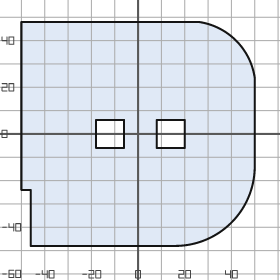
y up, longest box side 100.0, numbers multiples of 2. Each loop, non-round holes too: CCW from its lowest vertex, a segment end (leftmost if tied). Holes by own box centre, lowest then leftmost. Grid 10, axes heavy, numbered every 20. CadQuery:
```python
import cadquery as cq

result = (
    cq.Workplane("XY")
    .moveTo(-46.0, -48.0)
    .lineTo(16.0, -48.0)
    .threePointArc((40.0, -38.0), (50.0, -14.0))
    .lineTo(50.0, 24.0)
    .threePointArc((42.0, 40.0), (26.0, 48.0))
    .lineTo(-50.0, 48.0)
    .lineTo(-50.0, -24.0)
    .lineTo(-46.0, -24.0)
    .close()
    .moveTo(-18.0, -6.0)
    .lineTo(-6.0, -6.0)
    .lineTo(-6.0, 6.0)
    .lineTo(-18.0, 6.0)
    .close()
    .moveTo(8.0, -6.0)
    .lineTo(20.0, -6.0)
    .lineTo(20.0, 6.0)
    .lineTo(8.0, 6.0)
    .close()
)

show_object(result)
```